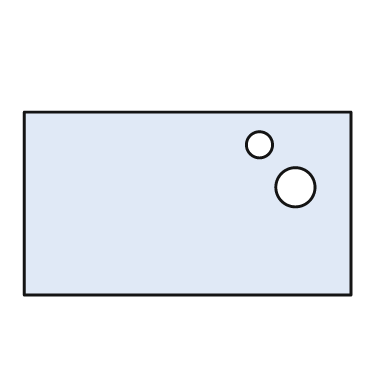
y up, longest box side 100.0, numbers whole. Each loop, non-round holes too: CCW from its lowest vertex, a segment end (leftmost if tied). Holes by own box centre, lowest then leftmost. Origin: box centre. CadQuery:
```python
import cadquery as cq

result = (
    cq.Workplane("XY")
    .moveTo(-50.0, -28.0)
    .lineTo(50.0, -28.0)
    .lineTo(50.0, 28.0)
    .lineTo(-50.0, 28.0)
    .close()
    .moveTo(33.0, 5.0)
    .circle(6.0)
    .moveTo(22.0, 18.0)
    .circle(4.0)
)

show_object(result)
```